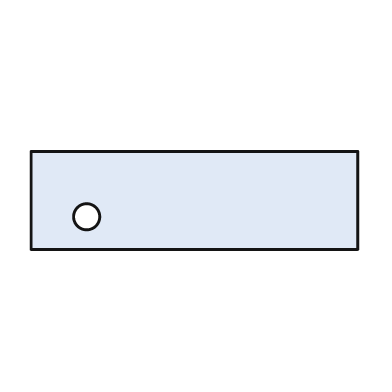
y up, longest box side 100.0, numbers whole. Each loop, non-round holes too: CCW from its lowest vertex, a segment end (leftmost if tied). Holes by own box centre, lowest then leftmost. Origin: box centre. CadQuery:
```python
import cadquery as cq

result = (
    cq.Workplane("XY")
    .moveTo(-50.0, -15.0)
    .lineTo(50.0, -15.0)
    .lineTo(50.0, 15.0)
    .lineTo(-50.0, 15.0)
    .close()
    .moveTo(-33.0, -5.0)
    .circle(4.0)
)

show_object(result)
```